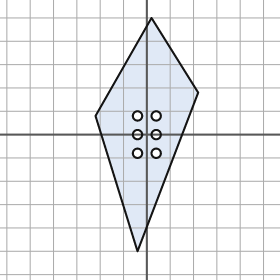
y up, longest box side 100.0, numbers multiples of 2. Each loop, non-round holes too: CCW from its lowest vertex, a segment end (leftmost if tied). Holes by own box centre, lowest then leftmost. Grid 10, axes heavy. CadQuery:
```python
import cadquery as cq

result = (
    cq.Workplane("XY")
    .moveTo(-4.0, -50.0)
    .lineTo(22.0, 18.0)
    .lineTo(2.0, 50.0)
    .lineTo(-22.0, 8.0)
    .close()
    .moveTo(-4.0, -8.0)
    .circle(2.0)
    .moveTo(4.0, -8.0)
    .circle(2.0)
    .moveTo(-4.0, 0.0)
    .circle(2.0)
    .moveTo(4.0, 0.0)
    .circle(2.0)
    .moveTo(-4.0, 8.0)
    .circle(2.0)
    .moveTo(4.0, 8.0)
    .circle(2.0)
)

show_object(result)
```